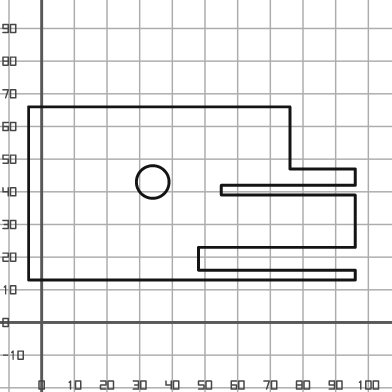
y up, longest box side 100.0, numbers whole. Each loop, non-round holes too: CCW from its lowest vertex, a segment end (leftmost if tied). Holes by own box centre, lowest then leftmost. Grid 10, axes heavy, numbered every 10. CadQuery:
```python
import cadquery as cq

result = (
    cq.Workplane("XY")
    .moveTo(-4.0, 13.0)
    .lineTo(96.0, 13.0)
    .lineTo(96.0, 16.0)
    .lineTo(48.0, 16.0)
    .lineTo(48.0, 23.0)
    .lineTo(96.0, 23.0)
    .lineTo(96.0, 39.0)
    .lineTo(55.0, 39.0)
    .lineTo(55.0, 42.0)
    .lineTo(96.0, 42.0)
    .lineTo(96.0, 47.0)
    .lineTo(76.0, 47.0)
    .lineTo(76.0, 66.0)
    .lineTo(-4.0, 66.0)
    .close()
    .moveTo(34.0, 43.0)
    .circle(5.0)
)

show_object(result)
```